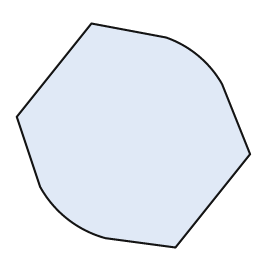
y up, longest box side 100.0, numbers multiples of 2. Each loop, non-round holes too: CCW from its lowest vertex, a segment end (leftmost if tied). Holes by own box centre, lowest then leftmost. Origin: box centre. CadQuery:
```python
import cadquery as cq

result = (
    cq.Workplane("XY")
    .moveTo(18.0, -48.0)
    .lineTo(50.0, -8.0)
    .lineTo(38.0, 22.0)
    .threePointArc((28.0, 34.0), (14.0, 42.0))
    .lineTo(-18.0, 48.0)
    .lineTo(-50.0, 8.0)
    .lineTo(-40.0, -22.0)
    .threePointArc((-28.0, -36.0), (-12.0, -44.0))
    .close()
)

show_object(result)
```